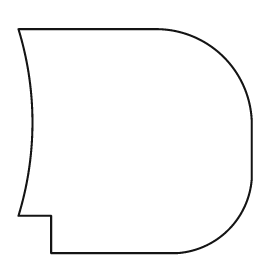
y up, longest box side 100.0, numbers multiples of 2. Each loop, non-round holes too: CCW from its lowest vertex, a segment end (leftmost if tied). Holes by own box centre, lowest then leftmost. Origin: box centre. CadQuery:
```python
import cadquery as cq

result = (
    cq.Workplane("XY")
    .moveTo(-36.0, -48.0)
    .lineTo(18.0, -48.0)
    .threePointArc((40.0, -38.0), (50.0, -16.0))
    .lineTo(50.0, 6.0)
    .threePointArc((38.0, 36.0), (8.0, 48.0))
    .lineTo(-50.0, 48.0)
    .threePointArc((-44.0, 8.0), (-50.0, -32.0))
    .lineTo(-36.0, -32.0)
    .close()
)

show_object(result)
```